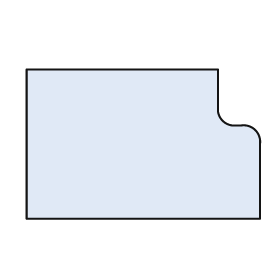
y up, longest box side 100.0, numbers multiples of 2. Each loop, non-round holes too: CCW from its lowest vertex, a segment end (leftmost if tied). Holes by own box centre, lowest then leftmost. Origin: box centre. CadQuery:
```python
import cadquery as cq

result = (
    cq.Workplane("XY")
    .moveTo(-50.0, -32.0)
    .lineTo(50.0, -32.0)
    .lineTo(50.0, 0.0)
    .threePointArc((48.0, 6.0), (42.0, 8.0))
    .lineTo(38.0, 8.0)
    .threePointArc((34.0, 10.0), (32.0, 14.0))
    .lineTo(32.0, 32.0)
    .lineTo(-50.0, 32.0)
    .close()
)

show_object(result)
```